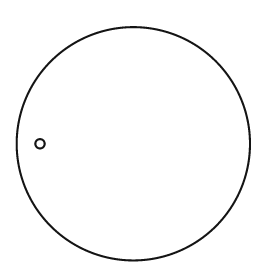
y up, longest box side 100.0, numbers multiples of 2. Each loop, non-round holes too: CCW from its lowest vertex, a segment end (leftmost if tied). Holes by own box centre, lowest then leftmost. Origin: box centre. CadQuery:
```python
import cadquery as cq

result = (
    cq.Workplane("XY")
    .moveTo(0.0, 0.0)
    .circle(50.0)
    .moveTo(-40.0, 0.0)
    .circle(2.0)
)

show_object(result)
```